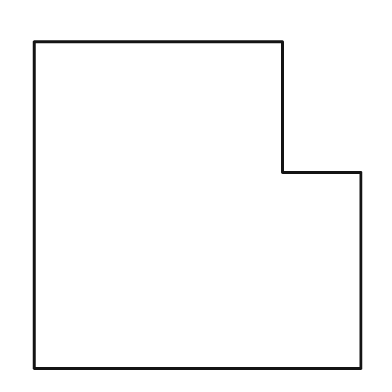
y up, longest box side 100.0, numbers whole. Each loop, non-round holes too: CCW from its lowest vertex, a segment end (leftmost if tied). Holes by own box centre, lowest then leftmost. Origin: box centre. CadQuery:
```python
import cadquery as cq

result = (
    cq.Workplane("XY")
    .moveTo(-50.0, -50.0)
    .lineTo(50.0, -50.0)
    .lineTo(50.0, 10.0)
    .lineTo(26.0, 10.0)
    .lineTo(26.0, 50.0)
    .lineTo(-50.0, 50.0)
    .close()
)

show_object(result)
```